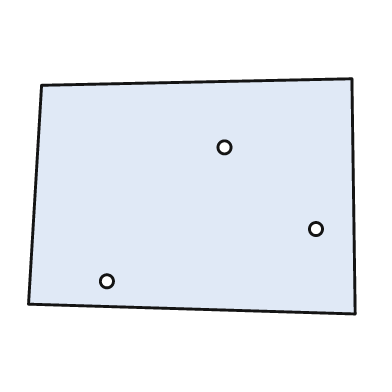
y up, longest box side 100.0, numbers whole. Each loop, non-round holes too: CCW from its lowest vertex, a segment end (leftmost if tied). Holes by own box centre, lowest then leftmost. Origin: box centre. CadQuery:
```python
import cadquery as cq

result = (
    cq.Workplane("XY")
    .moveTo(50.0, -36.0)
    .lineTo(49.0, 36.0)
    .lineTo(-46.0, 34.0)
    .lineTo(-50.0, -33.0)
    .close()
    .moveTo(-26.0, -26.0)
    .circle(2.0)
    .moveTo(38.0, -10.0)
    .circle(2.0)
    .moveTo(10.0, 15.0)
    .circle(2.0)
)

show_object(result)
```